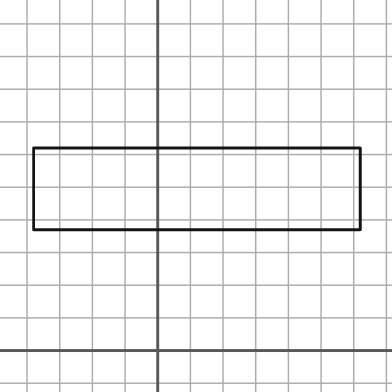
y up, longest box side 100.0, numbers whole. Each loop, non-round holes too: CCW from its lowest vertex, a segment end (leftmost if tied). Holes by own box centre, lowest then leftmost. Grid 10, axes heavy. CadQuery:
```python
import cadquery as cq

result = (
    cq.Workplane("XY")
    .moveTo(-38.0, 37.0)
    .lineTo(62.0, 37.0)
    .lineTo(62.0, 62.0)
    .lineTo(-38.0, 62.0)
    .close()
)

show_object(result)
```